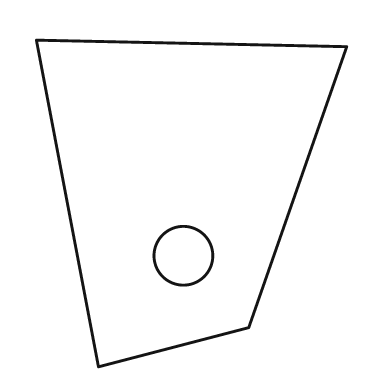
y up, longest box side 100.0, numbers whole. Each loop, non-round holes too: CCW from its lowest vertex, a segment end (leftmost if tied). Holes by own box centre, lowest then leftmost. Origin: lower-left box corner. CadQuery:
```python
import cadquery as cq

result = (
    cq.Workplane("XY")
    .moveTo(19.0, 0.0)
    .lineTo(65.0, 12.0)
    .lineTo(95.0, 98.0)
    .lineTo(0.0, 100.0)
    .close()
    .moveTo(45.0, 34.0)
    .circle(9.0)
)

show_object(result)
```